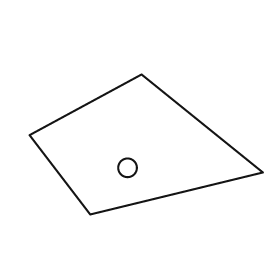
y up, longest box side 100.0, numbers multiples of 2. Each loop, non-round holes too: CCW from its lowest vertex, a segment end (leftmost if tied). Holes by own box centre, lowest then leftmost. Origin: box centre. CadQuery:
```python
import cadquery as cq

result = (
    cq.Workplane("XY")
    .moveTo(-24.0, -30.0)
    .lineTo(50.0, -12.0)
    .lineTo(-2.0, 30.0)
    .lineTo(-50.0, 4.0)
    .close()
    .moveTo(-8.0, -10.0)
    .circle(4.0)
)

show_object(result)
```